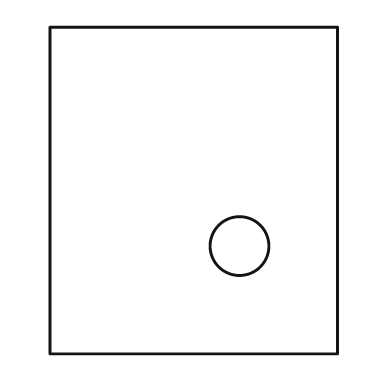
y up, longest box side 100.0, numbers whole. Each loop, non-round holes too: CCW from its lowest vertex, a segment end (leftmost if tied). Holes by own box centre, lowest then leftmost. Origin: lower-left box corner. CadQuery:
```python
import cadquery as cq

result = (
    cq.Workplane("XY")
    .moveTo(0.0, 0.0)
    .lineTo(88.0, 0.0)
    .lineTo(88.0, 100.0)
    .lineTo(0.0, 100.0)
    .close()
    .moveTo(58.0, 33.0)
    .circle(9.0)
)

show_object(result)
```